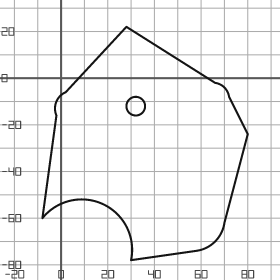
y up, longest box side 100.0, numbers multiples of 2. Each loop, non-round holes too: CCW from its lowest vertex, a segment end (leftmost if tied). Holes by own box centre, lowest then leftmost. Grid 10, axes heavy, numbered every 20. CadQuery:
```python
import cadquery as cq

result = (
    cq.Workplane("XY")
    .moveTo(30.0, -78.0)
    .lineTo(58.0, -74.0)
    .threePointArc((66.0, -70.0), (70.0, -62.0))
    .lineTo(80.0, -24.0)
    .lineTo(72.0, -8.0)
    .threePointArc((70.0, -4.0), (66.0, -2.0))
    .lineTo(28.0, 22.0)
    .lineTo(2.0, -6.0)
    .threePointArc((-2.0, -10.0), (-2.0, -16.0))
    .lineTo(-8.0, -60.0)
    .threePointArc((18.0, -54.0), (30.0, -78.0))
    .close()
    .moveTo(32.0, -12.0)
    .circle(4.0)
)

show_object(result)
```